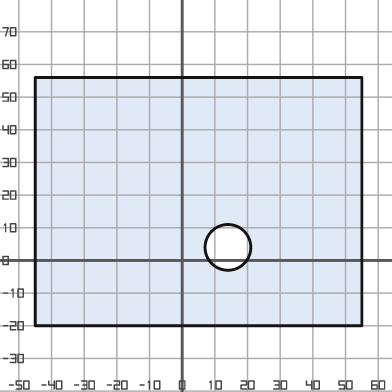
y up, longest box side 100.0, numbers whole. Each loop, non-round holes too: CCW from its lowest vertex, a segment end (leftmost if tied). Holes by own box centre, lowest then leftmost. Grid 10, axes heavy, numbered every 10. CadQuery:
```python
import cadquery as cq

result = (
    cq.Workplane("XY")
    .moveTo(-45.0, -20.0)
    .lineTo(55.0, -20.0)
    .lineTo(55.0, 56.0)
    .lineTo(-45.0, 56.0)
    .close()
    .moveTo(14.0, 4.0)
    .circle(7.0)
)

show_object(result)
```